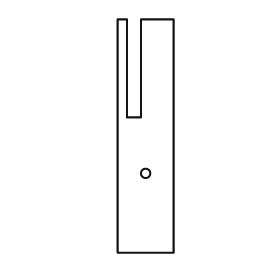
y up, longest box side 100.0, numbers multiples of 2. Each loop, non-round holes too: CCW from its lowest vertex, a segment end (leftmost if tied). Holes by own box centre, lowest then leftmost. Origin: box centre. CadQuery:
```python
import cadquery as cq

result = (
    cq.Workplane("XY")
    .moveTo(-12.0, -50.0)
    .lineTo(12.0, -50.0)
    .lineTo(12.0, 50.0)
    .lineTo(-2.0, 50.0)
    .lineTo(-2.0, 8.0)
    .lineTo(-8.0, 8.0)
    .lineTo(-8.0, 50.0)
    .lineTo(-12.0, 50.0)
    .close()
    .moveTo(0.0, -16.0)
    .circle(2.0)
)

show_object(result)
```